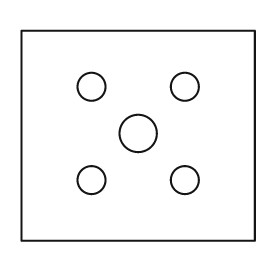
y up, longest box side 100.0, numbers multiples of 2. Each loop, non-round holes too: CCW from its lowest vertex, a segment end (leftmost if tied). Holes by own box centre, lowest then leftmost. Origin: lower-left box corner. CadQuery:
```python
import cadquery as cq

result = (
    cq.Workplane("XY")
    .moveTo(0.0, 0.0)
    .lineTo(100.0, 0.0)
    .lineTo(100.0, 90.0)
    .lineTo(0.0, 90.0)
    .close()
    .moveTo(30.0, 26.0)
    .circle(6.0)
    .moveTo(70.0, 26.0)
    .circle(6.0)
    .moveTo(50.0, 46.0)
    .circle(8.0)
    .moveTo(30.0, 66.0)
    .circle(6.0)
    .moveTo(70.0, 66.0)
    .circle(6.0)
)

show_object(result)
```